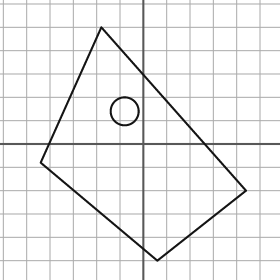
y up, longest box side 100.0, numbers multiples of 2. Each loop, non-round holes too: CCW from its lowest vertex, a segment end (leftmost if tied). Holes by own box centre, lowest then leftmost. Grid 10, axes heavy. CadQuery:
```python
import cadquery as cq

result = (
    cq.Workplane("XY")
    .moveTo(6.0, -50.0)
    .lineTo(44.0, -20.0)
    .lineTo(-18.0, 50.0)
    .lineTo(-44.0, -8.0)
    .close()
    .moveTo(-8.0, 14.0)
    .circle(6.0)
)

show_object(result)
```